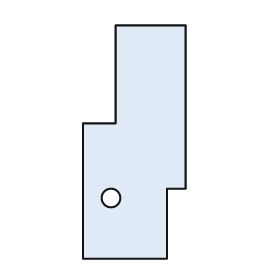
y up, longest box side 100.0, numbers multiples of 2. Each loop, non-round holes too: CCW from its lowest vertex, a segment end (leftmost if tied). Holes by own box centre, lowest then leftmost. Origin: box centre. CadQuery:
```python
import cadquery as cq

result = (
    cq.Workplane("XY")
    .moveTo(-22.0, -50.0)
    .lineTo(14.0, -50.0)
    .lineTo(14.0, -20.0)
    .lineTo(22.0, -20.0)
    .lineTo(22.0, 50.0)
    .lineTo(-8.0, 50.0)
    .lineTo(-8.0, 8.0)
    .lineTo(-22.0, 8.0)
    .close()
    .moveTo(-10.0, -24.0)
    .circle(4.0)
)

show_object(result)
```